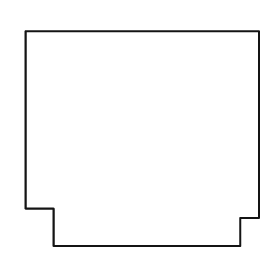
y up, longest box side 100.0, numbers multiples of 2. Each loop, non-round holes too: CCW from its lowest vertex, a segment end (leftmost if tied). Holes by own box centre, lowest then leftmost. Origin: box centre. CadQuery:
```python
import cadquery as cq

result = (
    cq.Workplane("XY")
    .moveTo(-38.0, -46.0)
    .lineTo(42.0, -46.0)
    .lineTo(42.0, -34.0)
    .lineTo(50.0, -34.0)
    .lineTo(50.0, 46.0)
    .lineTo(-50.0, 46.0)
    .lineTo(-50.0, -30.0)
    .lineTo(-38.0, -30.0)
    .close()
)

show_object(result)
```